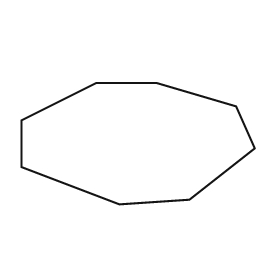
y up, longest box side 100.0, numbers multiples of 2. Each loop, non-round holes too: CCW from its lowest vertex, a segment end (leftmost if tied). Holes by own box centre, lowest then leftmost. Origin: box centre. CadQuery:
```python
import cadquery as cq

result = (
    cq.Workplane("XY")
    .moveTo(-8.0, -26.0)
    .lineTo(22.0, -24.0)
    .lineTo(50.0, -2.0)
    .lineTo(42.0, 16.0)
    .lineTo(8.0, 26.0)
    .lineTo(-18.0, 26.0)
    .lineTo(-50.0, 10.0)
    .lineTo(-50.0, -10.0)
    .close()
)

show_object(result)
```